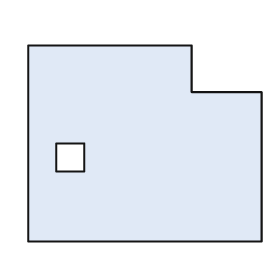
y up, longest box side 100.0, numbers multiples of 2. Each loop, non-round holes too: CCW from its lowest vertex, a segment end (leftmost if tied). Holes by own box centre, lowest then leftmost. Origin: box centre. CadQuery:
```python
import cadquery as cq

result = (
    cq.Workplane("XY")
    .moveTo(-50.0, -42.0)
    .lineTo(50.0, -42.0)
    .lineTo(50.0, 22.0)
    .lineTo(20.0, 22.0)
    .lineTo(20.0, 42.0)
    .lineTo(-50.0, 42.0)
    .close()
    .moveTo(-38.0, -12.0)
    .lineTo(-26.0, -12.0)
    .lineTo(-26.0, 0.0)
    .lineTo(-38.0, 0.0)
    .close()
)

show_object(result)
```